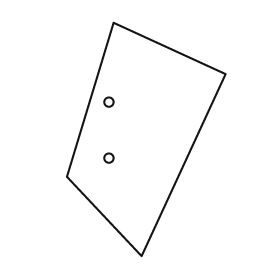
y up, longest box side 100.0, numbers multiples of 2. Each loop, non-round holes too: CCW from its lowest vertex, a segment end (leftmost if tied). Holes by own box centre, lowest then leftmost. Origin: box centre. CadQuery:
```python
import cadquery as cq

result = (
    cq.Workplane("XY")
    .moveTo(-2.0, -50.0)
    .lineTo(34.0, 28.0)
    .lineTo(-14.0, 50.0)
    .lineTo(-34.0, -16.0)
    .close()
    .moveTo(-16.0, -8.0)
    .circle(2.0)
    .moveTo(-16.0, 16.0)
    .circle(2.0)
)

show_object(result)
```